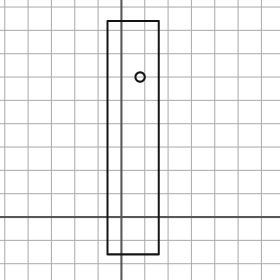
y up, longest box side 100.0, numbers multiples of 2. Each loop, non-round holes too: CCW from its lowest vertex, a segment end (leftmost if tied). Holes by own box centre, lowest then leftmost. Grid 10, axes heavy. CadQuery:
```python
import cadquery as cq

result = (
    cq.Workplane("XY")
    .moveTo(-6.0, -16.0)
    .lineTo(16.0, -16.0)
    .lineTo(16.0, 84.0)
    .lineTo(-6.0, 84.0)
    .close()
    .moveTo(8.0, 60.0)
    .circle(2.0)
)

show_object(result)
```